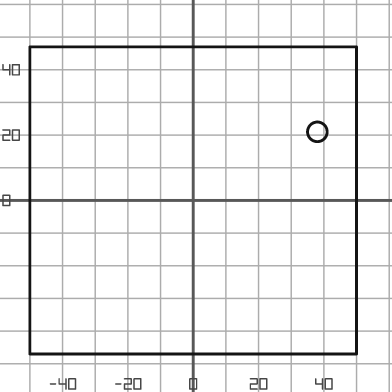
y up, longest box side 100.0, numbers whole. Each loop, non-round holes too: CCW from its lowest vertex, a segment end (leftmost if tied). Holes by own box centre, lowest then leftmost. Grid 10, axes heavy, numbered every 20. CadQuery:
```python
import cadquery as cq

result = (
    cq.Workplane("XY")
    .moveTo(-50.0, -47.0)
    .lineTo(50.0, -47.0)
    .lineTo(50.0, 47.0)
    .lineTo(-50.0, 47.0)
    .close()
    .moveTo(38.0, 21.0)
    .circle(3.0)
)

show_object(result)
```